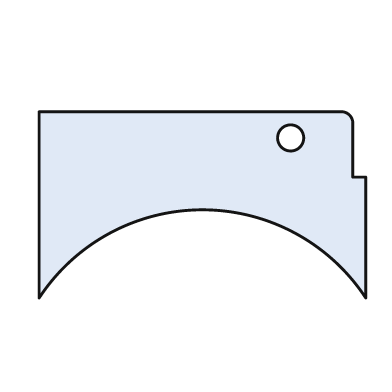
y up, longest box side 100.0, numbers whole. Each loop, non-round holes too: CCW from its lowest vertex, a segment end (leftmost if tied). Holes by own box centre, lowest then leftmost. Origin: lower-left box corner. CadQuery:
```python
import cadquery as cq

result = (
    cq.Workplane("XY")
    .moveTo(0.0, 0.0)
    .threePointArc((50.0, 27.0), (100.0, 0.0))
    .lineTo(100.0, 37.0)
    .lineTo(96.0, 37.0)
    .lineTo(96.0, 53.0)
    .threePointArc((95.0, 56.0), (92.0, 57.0))
    .lineTo(0.0, 57.0)
    .close()
    .moveTo(77.0, 49.0)
    .circle(4.0)
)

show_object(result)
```